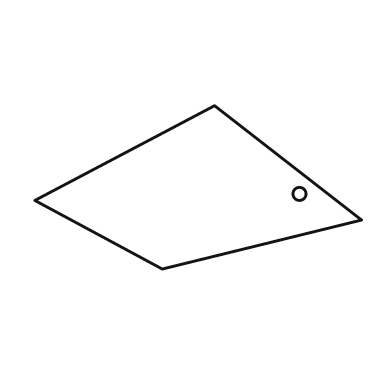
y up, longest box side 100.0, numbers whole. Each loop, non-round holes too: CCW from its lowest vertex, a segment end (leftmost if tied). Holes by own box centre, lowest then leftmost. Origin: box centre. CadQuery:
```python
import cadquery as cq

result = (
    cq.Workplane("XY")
    .moveTo(-11.0, -25.0)
    .lineTo(50.0, -10.0)
    .lineTo(5.0, 25.0)
    .lineTo(-50.0, -4.0)
    .close()
    .moveTo(31.0, -2.0)
    .circle(2.0)
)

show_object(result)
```